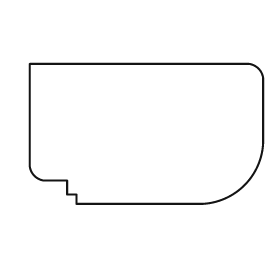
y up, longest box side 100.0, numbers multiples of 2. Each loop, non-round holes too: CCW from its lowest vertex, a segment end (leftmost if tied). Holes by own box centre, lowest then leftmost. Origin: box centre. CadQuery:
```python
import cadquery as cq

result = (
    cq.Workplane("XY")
    .moveTo(-30.0, -30.0)
    .lineTo(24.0, -30.0)
    .threePointArc((42.0, -22.0), (50.0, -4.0))
    .lineTo(50.0, 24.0)
    .threePointArc((48.0, 28.0), (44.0, 30.0))
    .lineTo(-50.0, 30.0)
    .lineTo(-50.0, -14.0)
    .threePointArc((-48.0, -18.0), (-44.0, -20.0))
    .lineTo(-34.0, -20.0)
    .lineTo(-34.0, -26.0)
    .lineTo(-30.0, -26.0)
    .close()
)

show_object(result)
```